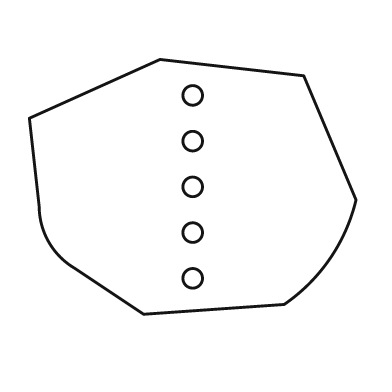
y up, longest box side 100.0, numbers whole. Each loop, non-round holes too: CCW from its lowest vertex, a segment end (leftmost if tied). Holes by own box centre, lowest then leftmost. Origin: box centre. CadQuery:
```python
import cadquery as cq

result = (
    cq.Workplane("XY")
    .moveTo(-15.0, -39.0)
    .lineTo(28.0, -36.0)
    .threePointArc((42.0, -22.0), (50.0, -4.0))
    .lineTo(34.0, 34.0)
    .lineTo(-10.0, 39.0)
    .lineTo(-50.0, 21.0)
    .lineTo(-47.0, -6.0)
    .threePointArc((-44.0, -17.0), (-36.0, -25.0))
    .close()
    .moveTo(0.0, -28.0)
    .circle(3.0)
    .moveTo(0.0, -14.0)
    .circle(3.0)
    .moveTo(0.0, 0.0)
    .circle(3.0)
    .moveTo(0.0, 14.0)
    .circle(3.0)
    .moveTo(0.0, 28.0)
    .circle(3.0)
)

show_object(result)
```